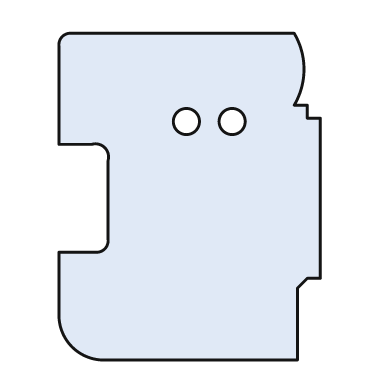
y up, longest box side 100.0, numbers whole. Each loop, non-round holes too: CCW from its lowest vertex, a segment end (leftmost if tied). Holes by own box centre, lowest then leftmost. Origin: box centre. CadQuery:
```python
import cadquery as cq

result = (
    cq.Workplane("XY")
    .moveTo(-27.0, -50.0)
    .lineTo(33.0, -50.0)
    .lineTo(33.0, -28.0)
    .lineTo(36.0, -25.0)
    .lineTo(40.0, -25.0)
    .lineTo(40.0, 24.0)
    .lineTo(36.0, 24.0)
    .lineTo(36.0, 28.0)
    .lineTo(32.0, 28.0)
    .threePointArc((35.0, 39.0), (32.0, 50.0))
    .lineTo(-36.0, 50.0)
    .threePointArc((-39.0, 49.0), (-40.0, 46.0))
    .lineTo(-40.0, 16.0)
    .lineTo(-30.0, 16.0)
    .threePointArc((-26.0, 15.0), (-25.0, 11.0))
    .lineTo(-25.0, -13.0)
    .threePointArc((-26.0, -16.0), (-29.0, -17.0))
    .lineTo(-40.0, -17.0)
    .lineTo(-40.0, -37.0)
    .threePointArc((-36.0, -46.0), (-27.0, -50.0))
    .close()
    .moveTo(-1.0, 23.0)
    .circle(4.0)
    .moveTo(13.0, 23.0)
    .circle(4.0)
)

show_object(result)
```